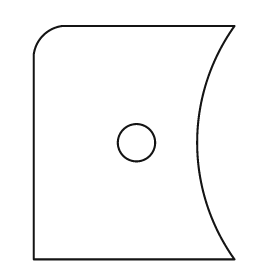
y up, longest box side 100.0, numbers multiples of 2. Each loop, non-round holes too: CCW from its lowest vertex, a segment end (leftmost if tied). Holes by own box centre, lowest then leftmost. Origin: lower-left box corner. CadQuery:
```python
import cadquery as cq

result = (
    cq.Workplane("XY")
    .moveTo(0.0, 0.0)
    .lineTo(86.0, 0.0)
    .threePointArc((70.0, 50.0), (86.0, 100.0))
    .lineTo(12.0, 100.0)
    .threePointArc((4.0, 96.0), (0.0, 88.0))
    .close()
    .moveTo(44.0, 50.0)
    .circle(8.0)
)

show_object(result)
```